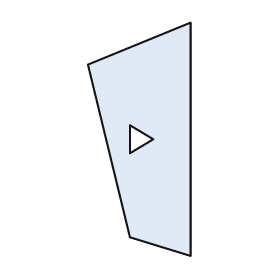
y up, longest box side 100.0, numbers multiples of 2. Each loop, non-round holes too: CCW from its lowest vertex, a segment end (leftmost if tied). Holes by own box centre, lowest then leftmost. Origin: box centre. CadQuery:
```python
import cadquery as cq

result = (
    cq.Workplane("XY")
    .moveTo(22.0, -50.0)
    .lineTo(22.0, 50.0)
    .lineTo(-22.0, 32.0)
    .lineTo(-4.0, -42.0)
    .close()
    .moveTo(-4.0, -6.0)
    .lineTo(6.0, 0.0)
    .lineTo(-4.0, 6.0)
    .close()
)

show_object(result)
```